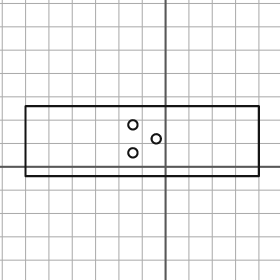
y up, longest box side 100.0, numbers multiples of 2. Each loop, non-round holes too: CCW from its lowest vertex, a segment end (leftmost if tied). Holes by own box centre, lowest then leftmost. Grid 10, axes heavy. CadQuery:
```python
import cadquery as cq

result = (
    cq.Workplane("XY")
    .moveTo(-60.0, -4.0)
    .lineTo(40.0, -4.0)
    .lineTo(40.0, 26.0)
    .lineTo(-60.0, 26.0)
    .close()
    .moveTo(-14.0, 6.0)
    .circle(2.0)
    .moveTo(-4.0, 12.0)
    .circle(2.0)
    .moveTo(-14.0, 18.0)
    .circle(2.0)
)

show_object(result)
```